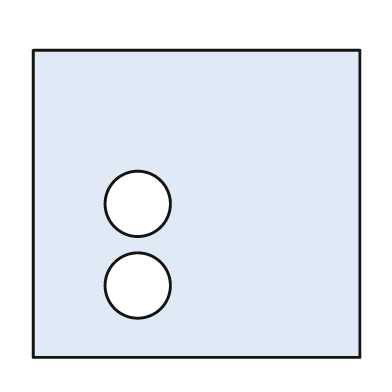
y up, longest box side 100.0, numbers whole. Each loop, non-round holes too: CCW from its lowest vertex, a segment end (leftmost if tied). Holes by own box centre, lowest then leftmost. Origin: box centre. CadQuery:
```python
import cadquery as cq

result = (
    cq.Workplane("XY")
    .moveTo(-50.0, -47.0)
    .lineTo(50.0, -47.0)
    .lineTo(50.0, 47.0)
    .lineTo(-50.0, 47.0)
    .close()
    .moveTo(-18.0, -25.0)
    .circle(10.0)
    .moveTo(-18.0, 0.0)
    .circle(10.0)
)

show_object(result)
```